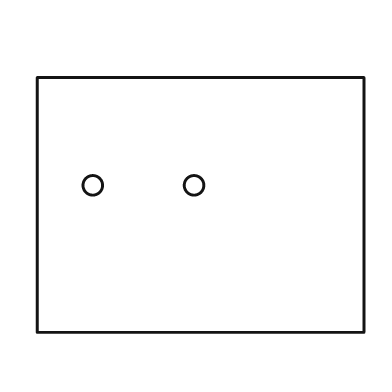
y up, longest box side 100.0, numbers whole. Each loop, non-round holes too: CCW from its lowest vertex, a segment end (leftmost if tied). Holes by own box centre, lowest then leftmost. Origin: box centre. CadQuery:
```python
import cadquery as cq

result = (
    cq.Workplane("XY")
    .moveTo(-50.0, -39.0)
    .lineTo(50.0, -39.0)
    .lineTo(50.0, 39.0)
    .lineTo(-50.0, 39.0)
    .close()
    .moveTo(-33.0, 6.0)
    .circle(3.0)
    .moveTo(-2.0, 6.0)
    .circle(3.0)
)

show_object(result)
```